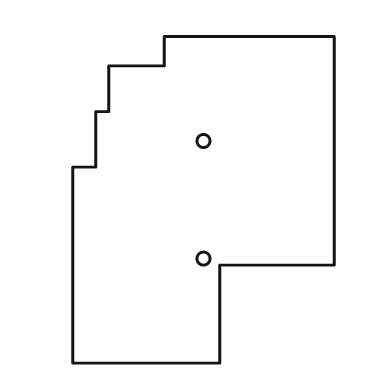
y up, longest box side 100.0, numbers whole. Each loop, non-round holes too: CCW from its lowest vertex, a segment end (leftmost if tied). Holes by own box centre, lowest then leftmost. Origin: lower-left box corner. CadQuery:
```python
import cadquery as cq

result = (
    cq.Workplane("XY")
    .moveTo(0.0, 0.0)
    .lineTo(45.0, 0.0)
    .lineTo(45.0, 30.0)
    .lineTo(80.0, 30.0)
    .lineTo(80.0, 100.0)
    .lineTo(28.0, 100.0)
    .lineTo(28.0, 91.0)
    .lineTo(11.0, 91.0)
    .lineTo(11.0, 77.0)
    .lineTo(7.0, 77.0)
    .lineTo(7.0, 60.0)
    .lineTo(0.0, 60.0)
    .close()
    .moveTo(40.0, 32.0)
    .circle(2.0)
    .moveTo(40.0, 68.0)
    .circle(2.0)
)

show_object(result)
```